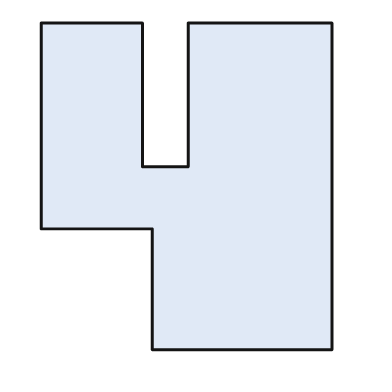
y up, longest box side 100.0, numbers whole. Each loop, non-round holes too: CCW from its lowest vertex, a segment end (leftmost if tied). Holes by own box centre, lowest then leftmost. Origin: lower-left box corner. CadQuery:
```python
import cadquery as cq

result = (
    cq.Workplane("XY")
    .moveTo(34.0, 0.0)
    .lineTo(89.0, 0.0)
    .lineTo(89.0, 100.0)
    .lineTo(45.0, 100.0)
    .lineTo(45.0, 56.0)
    .lineTo(31.0, 56.0)
    .lineTo(31.0, 100.0)
    .lineTo(0.0, 100.0)
    .lineTo(0.0, 37.0)
    .lineTo(34.0, 37.0)
    .close()
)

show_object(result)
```